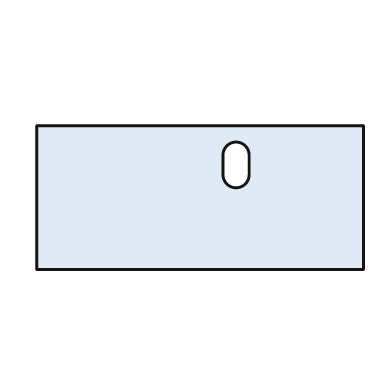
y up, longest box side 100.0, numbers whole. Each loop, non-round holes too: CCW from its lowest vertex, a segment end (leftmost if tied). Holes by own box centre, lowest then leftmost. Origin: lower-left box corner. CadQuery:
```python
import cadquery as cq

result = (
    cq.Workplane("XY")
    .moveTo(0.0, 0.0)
    .lineTo(100.0, 0.0)
    .lineTo(100.0, 44.0)
    .lineTo(0.0, 44.0)
    .close()
    .moveTo(57.0, 29.0)
    .threePointArc((61.0, 25.0), (65.0, 29.0))
    .lineTo(65.0, 35.0)
    .threePointArc((61.0, 39.0), (57.0, 35.0))
    .close()
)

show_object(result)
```